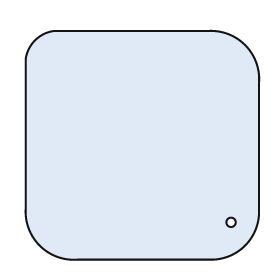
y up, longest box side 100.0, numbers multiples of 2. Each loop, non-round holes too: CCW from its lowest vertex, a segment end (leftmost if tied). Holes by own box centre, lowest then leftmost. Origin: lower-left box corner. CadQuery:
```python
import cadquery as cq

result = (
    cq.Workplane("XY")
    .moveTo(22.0, 0.0)
    .lineTo(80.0, 0.0)
    .threePointArc((94.0, 6.0), (100.0, 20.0))
    .lineTo(100.0, 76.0)
    .threePointArc((94.0, 92.0), (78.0, 98.0))
    .lineTo(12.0, 98.0)
    .threePointArc((4.0, 94.0), (0.0, 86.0))
    .lineTo(0.0, 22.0)
    .threePointArc((6.0, 6.0), (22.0, 0.0))
    .close()
    .moveTo(88.0, 16.0)
    .circle(2.0)
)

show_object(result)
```